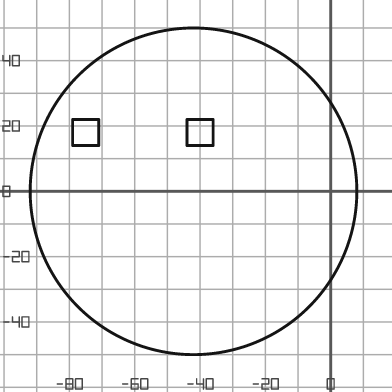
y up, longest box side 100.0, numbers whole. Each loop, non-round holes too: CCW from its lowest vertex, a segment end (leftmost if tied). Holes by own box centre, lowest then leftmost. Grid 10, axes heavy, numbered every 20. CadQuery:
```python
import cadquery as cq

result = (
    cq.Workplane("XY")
    .moveTo(-42.0, 0.0)
    .circle(50.0)
    .moveTo(-79.0, 14.0)
    .lineTo(-71.0, 14.0)
    .lineTo(-71.0, 22.0)
    .lineTo(-79.0, 22.0)
    .close()
    .moveTo(-44.0, 14.0)
    .lineTo(-36.0, 14.0)
    .lineTo(-36.0, 22.0)
    .lineTo(-44.0, 22.0)
    .close()
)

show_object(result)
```